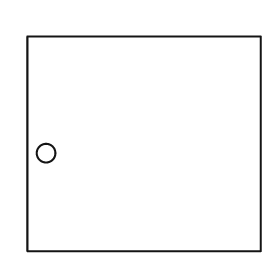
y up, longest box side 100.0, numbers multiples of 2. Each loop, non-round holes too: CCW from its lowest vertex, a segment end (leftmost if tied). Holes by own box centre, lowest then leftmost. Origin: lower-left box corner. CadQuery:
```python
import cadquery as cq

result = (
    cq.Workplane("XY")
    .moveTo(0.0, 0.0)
    .lineTo(100.0, 0.0)
    .lineTo(100.0, 92.0)
    .lineTo(0.0, 92.0)
    .close()
    .moveTo(8.0, 42.0)
    .circle(4.0)
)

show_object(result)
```